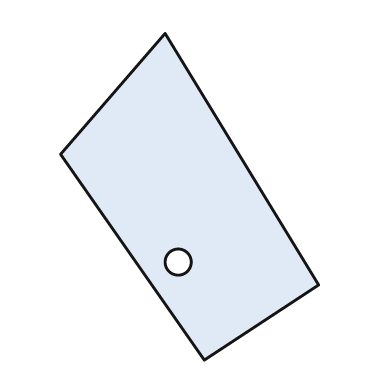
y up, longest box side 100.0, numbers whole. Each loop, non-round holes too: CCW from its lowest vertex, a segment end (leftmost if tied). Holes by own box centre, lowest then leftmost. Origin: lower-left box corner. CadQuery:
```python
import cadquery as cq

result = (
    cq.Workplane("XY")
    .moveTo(44.0, 0.0)
    .lineTo(79.0, 23.0)
    .lineTo(32.0, 100.0)
    .lineTo(0.0, 63.0)
    .close()
    .moveTo(36.0, 30.0)
    .circle(4.0)
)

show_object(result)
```